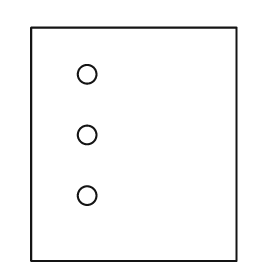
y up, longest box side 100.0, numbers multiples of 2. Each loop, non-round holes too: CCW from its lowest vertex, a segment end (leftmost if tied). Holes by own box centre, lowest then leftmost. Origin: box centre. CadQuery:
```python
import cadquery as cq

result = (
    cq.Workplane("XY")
    .moveTo(-44.0, -50.0)
    .lineTo(44.0, -50.0)
    .lineTo(44.0, 50.0)
    .lineTo(-44.0, 50.0)
    .close()
    .moveTo(-20.0, -22.0)
    .circle(4.0)
    .moveTo(-20.0, 4.0)
    .circle(4.0)
    .moveTo(-20.0, 30.0)
    .circle(4.0)
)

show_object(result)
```